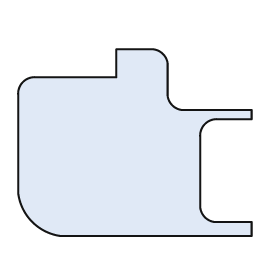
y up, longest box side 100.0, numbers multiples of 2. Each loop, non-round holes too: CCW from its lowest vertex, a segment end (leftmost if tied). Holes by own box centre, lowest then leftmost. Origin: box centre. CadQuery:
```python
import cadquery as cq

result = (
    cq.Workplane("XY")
    .moveTo(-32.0, -40.0)
    .lineTo(50.0, -40.0)
    .lineTo(50.0, -34.0)
    .lineTo(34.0, -34.0)
    .threePointArc((30.0, -32.0), (28.0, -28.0))
    .lineTo(28.0, 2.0)
    .threePointArc((30.0, 8.0), (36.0, 10.0))
    .lineTo(50.0, 10.0)
    .lineTo(50.0, 14.0)
    .lineTo(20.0, 14.0)
    .threePointArc((16.0, 16.0), (14.0, 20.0))
    .lineTo(14.0, 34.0)
    .threePointArc((12.0, 38.0), (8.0, 40.0))
    .lineTo(-8.0, 40.0)
    .lineTo(-8.0, 28.0)
    .lineTo(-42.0, 28.0)
    .threePointArc((-48.0, 26.0), (-50.0, 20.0))
    .lineTo(-50.0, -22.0)
    .threePointArc((-44.0, -34.0), (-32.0, -40.0))
    .close()
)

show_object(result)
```